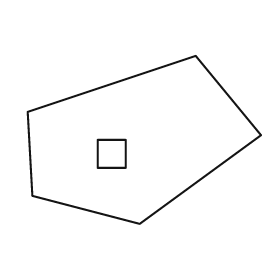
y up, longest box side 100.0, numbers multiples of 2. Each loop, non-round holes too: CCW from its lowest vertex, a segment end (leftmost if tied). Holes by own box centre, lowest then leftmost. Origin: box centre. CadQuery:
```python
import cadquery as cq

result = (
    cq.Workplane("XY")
    .moveTo(-2.0, -36.0)
    .lineTo(50.0, 2.0)
    .lineTo(22.0, 36.0)
    .lineTo(-50.0, 12.0)
    .lineTo(-48.0, -24.0)
    .close()
    .moveTo(-20.0, -12.0)
    .lineTo(-8.0, -12.0)
    .lineTo(-8.0, 0.0)
    .lineTo(-20.0, 0.0)
    .close()
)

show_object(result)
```